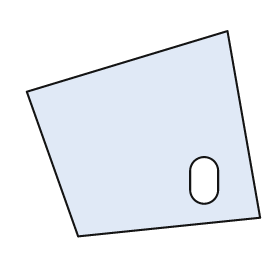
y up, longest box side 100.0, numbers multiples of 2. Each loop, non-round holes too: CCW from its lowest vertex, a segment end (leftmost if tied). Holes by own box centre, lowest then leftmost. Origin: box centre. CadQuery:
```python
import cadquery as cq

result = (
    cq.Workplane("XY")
    .moveTo(-28.0, -44.0)
    .lineTo(50.0, -36.0)
    .lineTo(36.0, 44.0)
    .lineTo(-50.0, 18.0)
    .close()
    .moveTo(20.0, -24.0)
    .threePointArc((26.0, -30.0), (32.0, -24.0))
    .lineTo(32.0, -16.0)
    .threePointArc((26.0, -10.0), (20.0, -16.0))
    .close()
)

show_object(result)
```